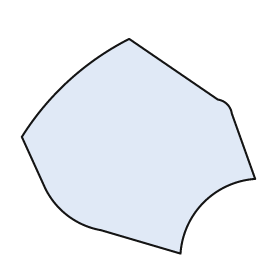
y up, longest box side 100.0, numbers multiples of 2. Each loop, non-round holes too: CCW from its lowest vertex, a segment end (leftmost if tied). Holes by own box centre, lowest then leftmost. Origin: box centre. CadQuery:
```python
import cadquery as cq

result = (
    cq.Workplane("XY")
    .moveTo(18.0, -46.0)
    .threePointArc((28.0, -24.0), (50.0, -14.0))
    .lineTo(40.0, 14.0)
    .threePointArc((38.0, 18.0), (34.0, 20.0))
    .lineTo(-4.0, 46.0)
    .threePointArc((-30.0, 28.0), (-50.0, 4.0))
    .lineTo(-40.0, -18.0)
    .threePointArc((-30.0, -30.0), (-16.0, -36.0))
    .close()
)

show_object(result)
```